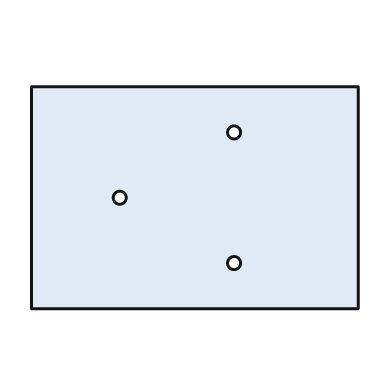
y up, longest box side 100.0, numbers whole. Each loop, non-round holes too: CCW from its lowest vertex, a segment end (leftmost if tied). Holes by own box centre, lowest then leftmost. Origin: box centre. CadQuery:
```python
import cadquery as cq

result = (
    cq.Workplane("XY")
    .moveTo(-50.0, -34.0)
    .lineTo(50.0, -34.0)
    .lineTo(50.0, 34.0)
    .lineTo(-50.0, 34.0)
    .close()
    .moveTo(12.0, -20.0)
    .circle(2.0)
    .moveTo(-23.0, 0.0)
    .circle(2.0)
    .moveTo(12.0, 20.0)
    .circle(2.0)
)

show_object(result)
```